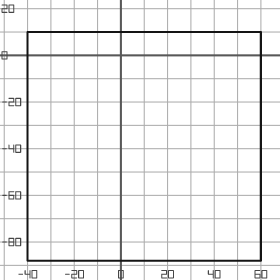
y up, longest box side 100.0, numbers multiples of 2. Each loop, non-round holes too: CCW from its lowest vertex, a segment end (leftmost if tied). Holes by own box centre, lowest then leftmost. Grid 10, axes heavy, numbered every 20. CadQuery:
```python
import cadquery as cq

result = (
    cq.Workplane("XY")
    .moveTo(-40.0, -88.0)
    .lineTo(60.0, -88.0)
    .lineTo(60.0, 10.0)
    .lineTo(-40.0, 10.0)
    .close()
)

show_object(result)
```